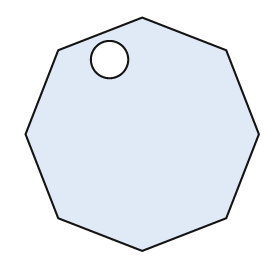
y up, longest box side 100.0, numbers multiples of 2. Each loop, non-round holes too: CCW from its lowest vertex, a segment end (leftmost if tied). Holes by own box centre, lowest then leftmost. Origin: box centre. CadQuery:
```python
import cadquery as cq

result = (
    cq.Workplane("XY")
    .moveTo(0.0, -50.0)
    .lineTo(36.0, -36.0)
    .lineTo(50.0, 0.0)
    .lineTo(36.0, 36.0)
    .lineTo(0.0, 50.0)
    .lineTo(-36.0, 36.0)
    .lineTo(-50.0, 0.0)
    .lineTo(-36.0, -36.0)
    .close()
    .moveTo(-14.0, 32.0)
    .circle(8.0)
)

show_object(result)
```